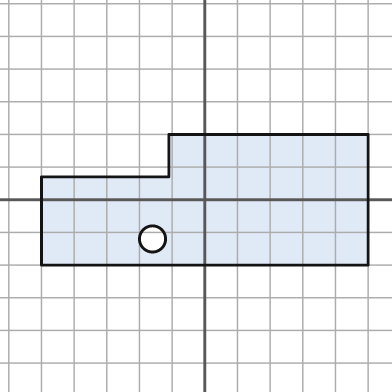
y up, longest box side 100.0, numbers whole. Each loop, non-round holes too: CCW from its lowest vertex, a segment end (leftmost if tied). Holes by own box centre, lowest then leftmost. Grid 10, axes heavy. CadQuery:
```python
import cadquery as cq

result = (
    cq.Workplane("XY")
    .moveTo(-50.0, -20.0)
    .lineTo(50.0, -20.0)
    .lineTo(50.0, 20.0)
    .lineTo(-11.0, 20.0)
    .lineTo(-11.0, 7.0)
    .lineTo(-50.0, 7.0)
    .close()
    .moveTo(-16.0, -12.0)
    .circle(4.0)
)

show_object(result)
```